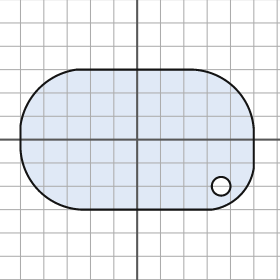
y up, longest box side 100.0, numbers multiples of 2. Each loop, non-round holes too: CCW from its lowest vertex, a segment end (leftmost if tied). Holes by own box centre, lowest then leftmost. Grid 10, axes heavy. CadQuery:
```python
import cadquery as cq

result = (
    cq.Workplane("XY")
    .moveTo(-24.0, -30.0)
    .lineTo(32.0, -30.0)
    .threePointArc((44.0, -24.0), (50.0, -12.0))
    .lineTo(50.0, 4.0)
    .threePointArc((42.0, 22.0), (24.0, 30.0))
    .lineTo(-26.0, 30.0)
    .threePointArc((-42.0, 22.0), (-50.0, 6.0))
    .lineTo(-50.0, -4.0)
    .threePointArc((-42.0, -22.0), (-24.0, -30.0))
    .close()
    .moveTo(36.0, -20.0)
    .circle(4.0)
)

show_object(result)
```